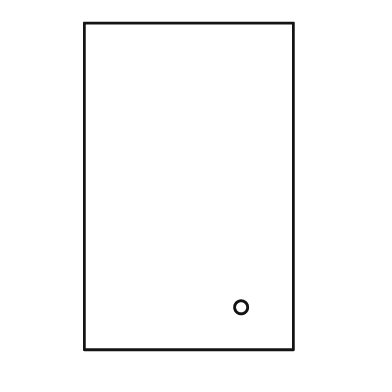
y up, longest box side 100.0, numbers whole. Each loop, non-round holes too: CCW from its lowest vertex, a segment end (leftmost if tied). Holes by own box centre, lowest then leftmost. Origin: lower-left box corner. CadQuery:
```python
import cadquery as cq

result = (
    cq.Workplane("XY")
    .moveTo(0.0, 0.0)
    .lineTo(64.0, 0.0)
    .lineTo(64.0, 100.0)
    .lineTo(0.0, 100.0)
    .close()
    .moveTo(48.0, 13.0)
    .circle(2.0)
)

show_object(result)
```